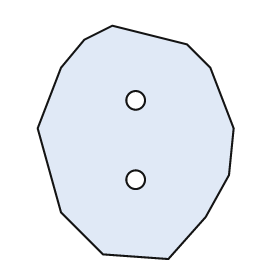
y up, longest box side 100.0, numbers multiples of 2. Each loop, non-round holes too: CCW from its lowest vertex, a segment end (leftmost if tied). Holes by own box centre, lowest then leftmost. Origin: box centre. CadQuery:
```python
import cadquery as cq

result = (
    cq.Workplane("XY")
    .moveTo(14.0, -50.0)
    .lineTo(30.0, -32.0)
    .lineTo(40.0, -14.0)
    .lineTo(42.0, 6.0)
    .lineTo(32.0, 32.0)
    .lineTo(22.0, 42.0)
    .lineTo(-10.0, 50.0)
    .lineTo(-22.0, 44.0)
    .lineTo(-32.0, 32.0)
    .lineTo(-42.0, 6.0)
    .lineTo(-32.0, -30.0)
    .lineTo(-14.0, -48.0)
    .close()
    .moveTo(0.0, -16.0)
    .circle(4.0)
    .moveTo(0.0, 18.0)
    .circle(4.0)
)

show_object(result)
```